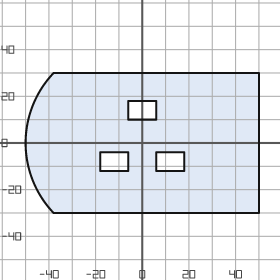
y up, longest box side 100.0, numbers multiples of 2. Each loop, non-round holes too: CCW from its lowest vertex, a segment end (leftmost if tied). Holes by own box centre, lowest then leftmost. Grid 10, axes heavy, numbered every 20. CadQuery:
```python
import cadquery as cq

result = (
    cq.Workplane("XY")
    .moveTo(-38.0, -30.0)
    .lineTo(50.0, -30.0)
    .lineTo(50.0, 30.0)
    .lineTo(-38.0, 30.0)
    .threePointArc((-50.0, 0.0), (-38.0, -30.0))
    .close()
    .moveTo(-18.0, -12.0)
    .lineTo(-6.0, -12.0)
    .lineTo(-6.0, -4.0)
    .lineTo(-18.0, -4.0)
    .close()
    .moveTo(6.0, -12.0)
    .lineTo(18.0, -12.0)
    .lineTo(18.0, -4.0)
    .lineTo(6.0, -4.0)
    .close()
    .moveTo(-6.0, 10.0)
    .lineTo(6.0, 10.0)
    .lineTo(6.0, 18.0)
    .lineTo(-6.0, 18.0)
    .close()
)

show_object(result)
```